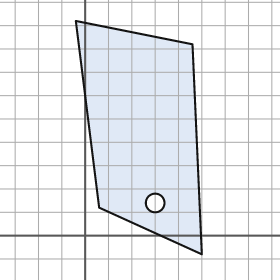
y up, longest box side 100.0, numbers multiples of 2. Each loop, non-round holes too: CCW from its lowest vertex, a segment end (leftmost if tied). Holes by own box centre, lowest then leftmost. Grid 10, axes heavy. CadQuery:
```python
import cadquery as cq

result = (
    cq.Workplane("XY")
    .moveTo(50.0, -8.0)
    .lineTo(46.0, 82.0)
    .lineTo(-4.0, 92.0)
    .lineTo(6.0, 12.0)
    .close()
    .moveTo(30.0, 14.0)
    .circle(4.0)
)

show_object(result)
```